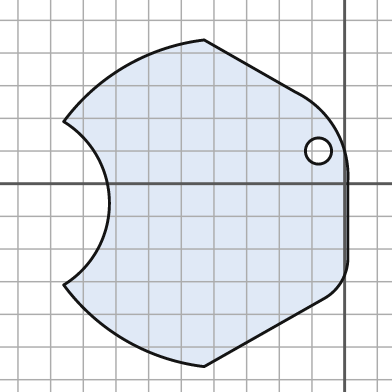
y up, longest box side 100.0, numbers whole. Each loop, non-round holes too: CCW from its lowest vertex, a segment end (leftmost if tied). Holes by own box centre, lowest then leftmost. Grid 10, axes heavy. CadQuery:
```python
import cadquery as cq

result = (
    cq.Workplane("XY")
    .moveTo(-43.0, -56.0)
    .lineTo(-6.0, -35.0)
    .threePointArc((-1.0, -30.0), (1.0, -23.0))
    .lineTo(1.0, 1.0)
    .threePointArc((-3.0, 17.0), (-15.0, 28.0))
    .lineTo(-43.0, 44.0)
    .threePointArc((-67.0, 36.0), (-86.0, 19.0))
    .threePointArc((-72.0, -6.0), (-86.0, -31.0))
    .threePointArc((-67.0, -48.0), (-43.0, -56.0))
    .close()
    .moveTo(-8.0, 10.0)
    .circle(4.0)
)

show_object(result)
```